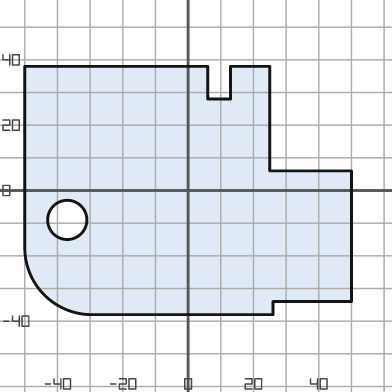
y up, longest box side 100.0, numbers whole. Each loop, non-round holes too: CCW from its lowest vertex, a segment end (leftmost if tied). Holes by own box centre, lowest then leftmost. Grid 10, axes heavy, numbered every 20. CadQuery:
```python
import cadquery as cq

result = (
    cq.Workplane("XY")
    .moveTo(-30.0, -38.0)
    .lineTo(26.0, -38.0)
    .lineTo(26.0, -34.0)
    .lineTo(50.0, -34.0)
    .lineTo(50.0, 6.0)
    .lineTo(25.0, 6.0)
    .lineTo(25.0, 38.0)
    .lineTo(13.0, 38.0)
    .lineTo(13.0, 28.0)
    .lineTo(6.0, 28.0)
    .lineTo(6.0, 38.0)
    .lineTo(-50.0, 38.0)
    .lineTo(-50.0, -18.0)
    .threePointArc((-44.0, -32.0), (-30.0, -38.0))
    .close()
    .moveTo(-37.0, -9.0)
    .circle(6.0)
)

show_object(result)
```